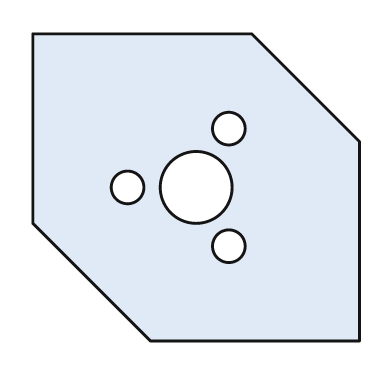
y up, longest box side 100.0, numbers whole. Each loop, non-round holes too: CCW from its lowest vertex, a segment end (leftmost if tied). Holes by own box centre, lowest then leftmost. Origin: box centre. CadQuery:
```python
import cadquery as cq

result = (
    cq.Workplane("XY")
    .moveTo(-14.0, -47.0)
    .lineTo(50.0, -47.0)
    .lineTo(50.0, 14.0)
    .lineTo(17.0, 47.0)
    .lineTo(-50.0, 47.0)
    .lineTo(-50.0, -11.0)
    .close()
    .moveTo(10.0, -18.0)
    .circle(5.0)
    .moveTo(-21.0, 0.0)
    .circle(5.0)
    .moveTo(0.0, 0.0)
    .circle(11.0)
    .moveTo(10.0, 18.0)
    .circle(5.0)
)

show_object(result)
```